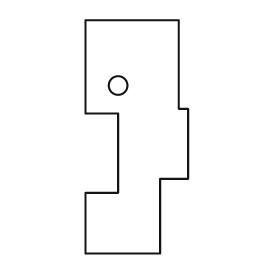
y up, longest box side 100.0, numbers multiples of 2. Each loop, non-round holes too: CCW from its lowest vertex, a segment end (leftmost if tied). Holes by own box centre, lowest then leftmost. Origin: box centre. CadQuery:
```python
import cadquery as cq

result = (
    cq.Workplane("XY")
    .moveTo(-22.0, -50.0)
    .lineTo(10.0, -50.0)
    .lineTo(10.0, -18.0)
    .lineTo(22.0, -18.0)
    .lineTo(22.0, 12.0)
    .lineTo(18.0, 12.0)
    .lineTo(18.0, 50.0)
    .lineTo(-22.0, 50.0)
    .lineTo(-22.0, 10.0)
    .lineTo(-8.0, 10.0)
    .lineTo(-8.0, -24.0)
    .lineTo(-22.0, -24.0)
    .close()
    .moveTo(-8.0, 22.0)
    .circle(4.0)
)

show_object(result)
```